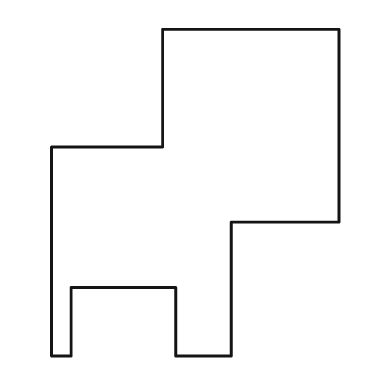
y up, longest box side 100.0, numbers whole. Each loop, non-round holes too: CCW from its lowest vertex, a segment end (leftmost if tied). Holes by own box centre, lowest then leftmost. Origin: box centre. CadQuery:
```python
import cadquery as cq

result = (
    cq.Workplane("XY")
    .moveTo(-44.0, -50.0)
    .lineTo(-38.0, -50.0)
    .lineTo(-38.0, -29.0)
    .lineTo(-6.0, -29.0)
    .lineTo(-6.0, -50.0)
    .lineTo(11.0, -50.0)
    .lineTo(11.0, -9.0)
    .lineTo(44.0, -9.0)
    .lineTo(44.0, 50.0)
    .lineTo(-10.0, 50.0)
    .lineTo(-10.0, 14.0)
    .lineTo(-44.0, 14.0)
    .close()
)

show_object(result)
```